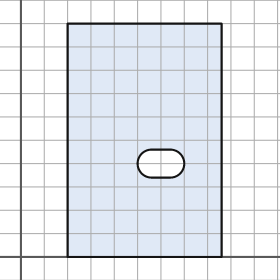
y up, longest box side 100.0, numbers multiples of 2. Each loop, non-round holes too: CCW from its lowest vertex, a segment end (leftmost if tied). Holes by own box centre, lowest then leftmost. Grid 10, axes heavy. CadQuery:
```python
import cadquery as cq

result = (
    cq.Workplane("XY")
    .moveTo(20.0, 0.0)
    .lineTo(86.0, 0.0)
    .lineTo(86.0, 100.0)
    .lineTo(20.0, 100.0)
    .close()
    .moveTo(56.0, 34.0)
    .lineTo(64.0, 34.0)
    .threePointArc((70.0, 40.0), (64.0, 46.0))
    .lineTo(56.0, 46.0)
    .threePointArc((50.0, 40.0), (56.0, 34.0))
    .close()
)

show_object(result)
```